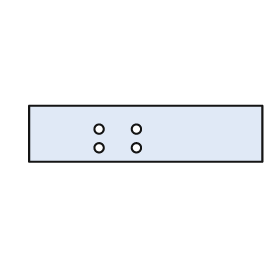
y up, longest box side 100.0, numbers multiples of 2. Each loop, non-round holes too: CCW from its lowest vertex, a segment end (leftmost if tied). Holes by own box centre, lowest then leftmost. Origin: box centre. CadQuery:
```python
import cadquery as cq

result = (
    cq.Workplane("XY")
    .moveTo(-50.0, -12.0)
    .lineTo(50.0, -12.0)
    .lineTo(50.0, 12.0)
    .lineTo(-50.0, 12.0)
    .close()
    .moveTo(-20.0, -6.0)
    .circle(2.0)
    .moveTo(-4.0, -6.0)
    .circle(2.0)
    .moveTo(-20.0, 2.0)
    .circle(2.0)
    .moveTo(-4.0, 2.0)
    .circle(2.0)
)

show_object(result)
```